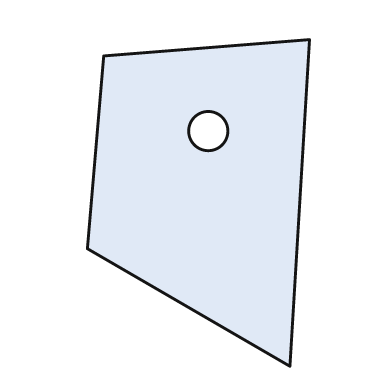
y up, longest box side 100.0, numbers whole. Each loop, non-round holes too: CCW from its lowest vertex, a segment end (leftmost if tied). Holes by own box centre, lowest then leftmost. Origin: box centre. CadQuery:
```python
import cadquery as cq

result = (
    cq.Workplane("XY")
    .moveTo(28.0, -50.0)
    .lineTo(34.0, 50.0)
    .lineTo(-29.0, 45.0)
    .lineTo(-34.0, -14.0)
    .close()
    .moveTo(3.0, 22.0)
    .circle(6.0)
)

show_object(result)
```